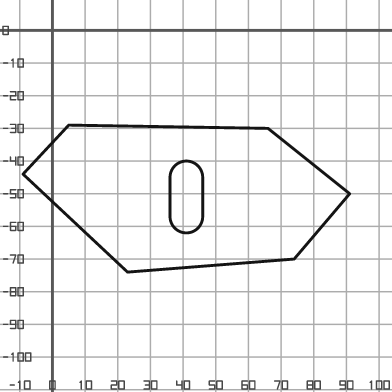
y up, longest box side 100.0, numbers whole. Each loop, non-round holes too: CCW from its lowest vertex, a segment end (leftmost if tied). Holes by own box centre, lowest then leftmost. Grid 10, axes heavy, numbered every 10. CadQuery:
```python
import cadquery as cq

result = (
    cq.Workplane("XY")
    .moveTo(23.0, -74.0)
    .lineTo(74.0, -70.0)
    .lineTo(91.0, -50.0)
    .lineTo(66.0, -30.0)
    .lineTo(5.0, -29.0)
    .lineTo(-9.0, -44.0)
    .close()
    .moveTo(36.0, -57.0)
    .threePointArc((41.0, -62.0), (46.0, -57.0))
    .lineTo(46.0, -45.0)
    .threePointArc((41.0, -40.0), (36.0, -45.0))
    .close()
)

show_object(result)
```